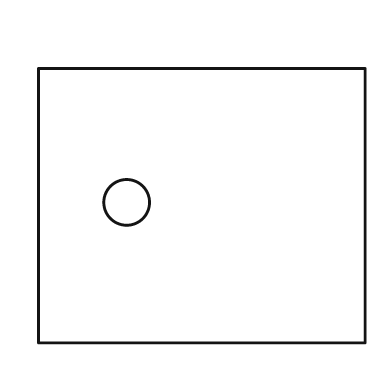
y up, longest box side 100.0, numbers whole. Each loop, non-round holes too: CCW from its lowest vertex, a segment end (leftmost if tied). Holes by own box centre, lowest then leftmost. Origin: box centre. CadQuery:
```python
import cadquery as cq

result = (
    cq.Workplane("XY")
    .moveTo(-50.0, -42.0)
    .lineTo(50.0, -42.0)
    .lineTo(50.0, 42.0)
    .lineTo(-50.0, 42.0)
    .close()
    .moveTo(-23.0, 1.0)
    .circle(7.0)
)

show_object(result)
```